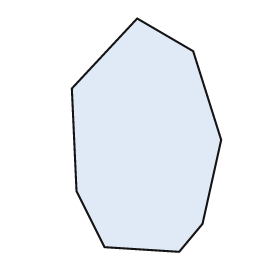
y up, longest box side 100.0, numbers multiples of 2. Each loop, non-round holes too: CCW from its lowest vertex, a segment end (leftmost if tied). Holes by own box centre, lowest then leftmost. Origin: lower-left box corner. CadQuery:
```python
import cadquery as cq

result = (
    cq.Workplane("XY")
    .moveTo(46.0, 0.0)
    .lineTo(56.0, 12.0)
    .lineTo(64.0, 48.0)
    .lineTo(52.0, 86.0)
    .lineTo(28.0, 100.0)
    .lineTo(0.0, 70.0)
    .lineTo(2.0, 26.0)
    .lineTo(14.0, 2.0)
    .close()
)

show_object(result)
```